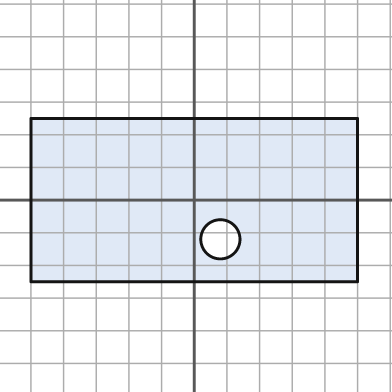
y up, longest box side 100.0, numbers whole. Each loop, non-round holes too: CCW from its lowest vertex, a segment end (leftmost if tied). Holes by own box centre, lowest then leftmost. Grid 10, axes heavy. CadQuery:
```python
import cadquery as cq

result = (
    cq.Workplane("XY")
    .moveTo(-50.0, -25.0)
    .lineTo(50.0, -25.0)
    .lineTo(50.0, 25.0)
    .lineTo(-50.0, 25.0)
    .close()
    .moveTo(8.0, -12.0)
    .circle(6.0)
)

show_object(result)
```